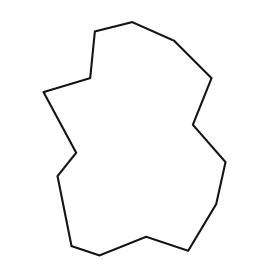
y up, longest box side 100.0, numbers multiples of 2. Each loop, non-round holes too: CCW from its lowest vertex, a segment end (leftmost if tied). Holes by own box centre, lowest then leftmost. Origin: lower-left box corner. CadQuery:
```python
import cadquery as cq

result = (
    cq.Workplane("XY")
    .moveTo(24.0, 0.0)
    .lineTo(44.0, 8.0)
    .lineTo(62.0, 2.0)
    .lineTo(74.0, 22.0)
    .lineTo(78.0, 40.0)
    .lineTo(64.0, 56.0)
    .lineTo(72.0, 76.0)
    .lineTo(56.0, 92.0)
    .lineTo(38.0, 100.0)
    .lineTo(22.0, 96.0)
    .lineTo(20.0, 76.0)
    .lineTo(0.0, 70.0)
    .lineTo(14.0, 44.0)
    .lineTo(6.0, 34.0)
    .lineTo(12.0, 4.0)
    .close()
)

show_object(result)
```